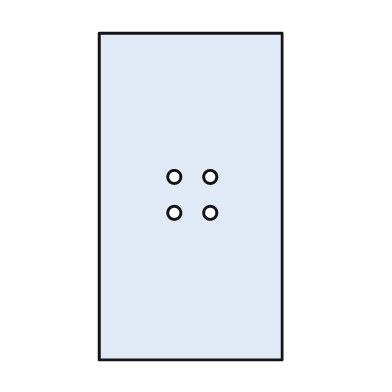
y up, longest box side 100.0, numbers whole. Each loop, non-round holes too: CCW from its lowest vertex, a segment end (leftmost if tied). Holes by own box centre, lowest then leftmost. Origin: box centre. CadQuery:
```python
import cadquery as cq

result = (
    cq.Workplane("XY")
    .moveTo(-28.0, -50.0)
    .lineTo(28.0, -50.0)
    .lineTo(28.0, 50.0)
    .lineTo(-28.0, 50.0)
    .close()
    .moveTo(-5.0, -5.0)
    .circle(2.0)
    .moveTo(6.0, -5.0)
    .circle(2.0)
    .moveTo(-5.0, 6.0)
    .circle(2.0)
    .moveTo(6.0, 6.0)
    .circle(2.0)
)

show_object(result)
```